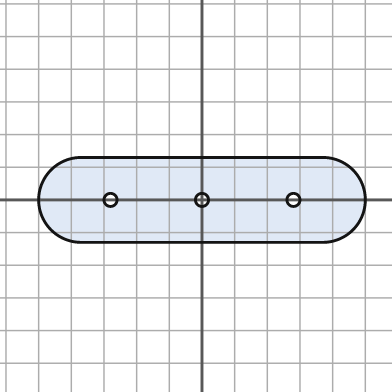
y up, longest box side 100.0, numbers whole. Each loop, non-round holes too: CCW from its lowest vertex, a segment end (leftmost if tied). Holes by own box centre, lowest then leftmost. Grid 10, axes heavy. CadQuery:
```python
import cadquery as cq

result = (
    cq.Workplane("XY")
    .moveTo(-37.0, -13.0)
    .lineTo(37.0, -13.0)
    .threePointArc((50.0, 0.0), (37.0, 13.0))
    .lineTo(-37.0, 13.0)
    .threePointArc((-50.0, 0.0), (-37.0, -13.0))
    .close()
    .moveTo(-28.0, 0.0)
    .circle(2.0)
    .moveTo(0.0, 0.0)
    .circle(2.0)
    .moveTo(28.0, 0.0)
    .circle(2.0)
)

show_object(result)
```